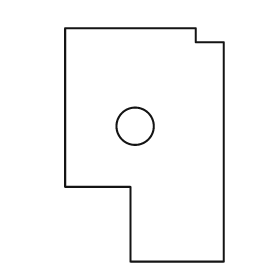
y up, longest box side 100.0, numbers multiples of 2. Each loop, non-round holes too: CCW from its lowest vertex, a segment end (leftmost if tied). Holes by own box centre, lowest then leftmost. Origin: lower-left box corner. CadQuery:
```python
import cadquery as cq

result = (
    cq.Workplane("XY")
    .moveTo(28.0, 0.0)
    .lineTo(68.0, 0.0)
    .lineTo(68.0, 94.0)
    .lineTo(56.0, 94.0)
    .lineTo(56.0, 100.0)
    .lineTo(0.0, 100.0)
    .lineTo(0.0, 32.0)
    .lineTo(28.0, 32.0)
    .close()
    .moveTo(30.0, 58.0)
    .circle(8.0)
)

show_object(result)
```